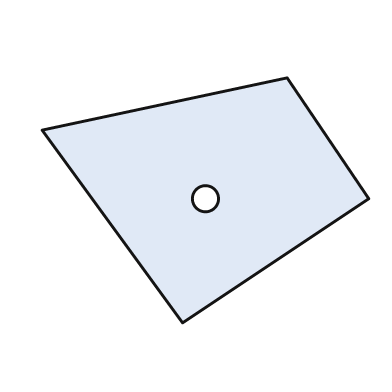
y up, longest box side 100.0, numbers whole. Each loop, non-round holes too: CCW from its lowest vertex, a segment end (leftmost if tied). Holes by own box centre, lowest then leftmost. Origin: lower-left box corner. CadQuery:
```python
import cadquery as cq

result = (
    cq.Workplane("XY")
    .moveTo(43.0, 0.0)
    .lineTo(100.0, 38.0)
    .lineTo(75.0, 75.0)
    .lineTo(0.0, 59.0)
    .close()
    .moveTo(50.0, 38.0)
    .circle(4.0)
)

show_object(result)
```